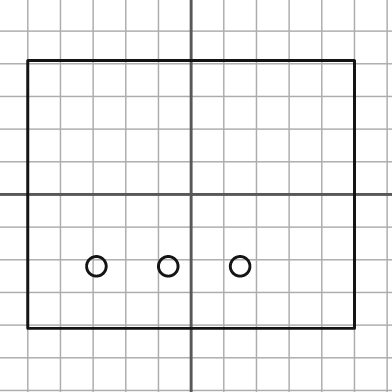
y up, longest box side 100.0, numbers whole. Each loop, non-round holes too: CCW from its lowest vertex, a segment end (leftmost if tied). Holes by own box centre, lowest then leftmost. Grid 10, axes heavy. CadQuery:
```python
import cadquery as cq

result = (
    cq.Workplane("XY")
    .moveTo(-50.0, -41.0)
    .lineTo(50.0, -41.0)
    .lineTo(50.0, 41.0)
    .lineTo(-50.0, 41.0)
    .close()
    .moveTo(-29.0, -22.0)
    .circle(3.0)
    .moveTo(-7.0, -22.0)
    .circle(3.0)
    .moveTo(15.0, -22.0)
    .circle(3.0)
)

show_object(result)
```